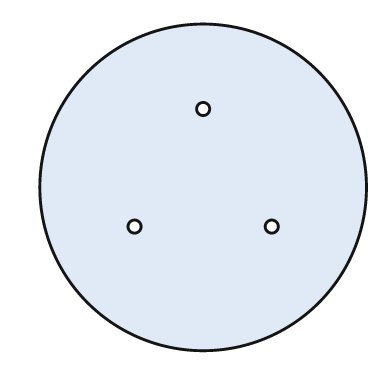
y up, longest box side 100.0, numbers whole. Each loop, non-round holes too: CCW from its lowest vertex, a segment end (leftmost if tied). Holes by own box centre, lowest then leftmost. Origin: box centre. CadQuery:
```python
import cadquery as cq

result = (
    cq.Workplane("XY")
    .moveTo(0.0, 0.0)
    .circle(50.0)
    .moveTo(-21.0, -12.0)
    .circle(2.0)
    .moveTo(21.0, -12.0)
    .circle(2.0)
    .moveTo(0.0, 24.0)
    .circle(2.0)
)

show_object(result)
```